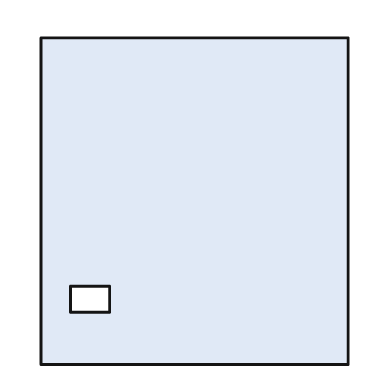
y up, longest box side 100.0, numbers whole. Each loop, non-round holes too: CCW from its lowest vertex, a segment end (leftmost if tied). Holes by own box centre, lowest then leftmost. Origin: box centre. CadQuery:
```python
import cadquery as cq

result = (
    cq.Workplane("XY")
    .moveTo(-47.0, -50.0)
    .lineTo(47.0, -50.0)
    .lineTo(47.0, 50.0)
    .lineTo(-47.0, 50.0)
    .close()
    .moveTo(-38.0, -34.0)
    .lineTo(-26.0, -34.0)
    .lineTo(-26.0, -26.0)
    .lineTo(-38.0, -26.0)
    .close()
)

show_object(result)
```